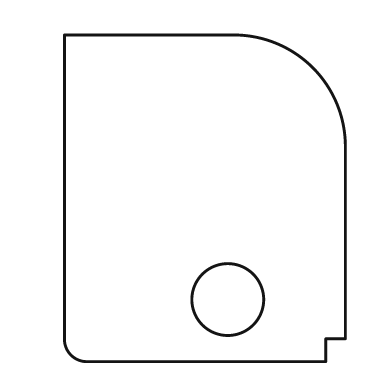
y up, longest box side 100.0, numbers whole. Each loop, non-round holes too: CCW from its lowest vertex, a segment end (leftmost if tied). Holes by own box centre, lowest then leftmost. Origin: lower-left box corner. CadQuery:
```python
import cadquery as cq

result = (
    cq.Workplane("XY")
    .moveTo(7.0, 0.0)
    .lineTo(80.0, 0.0)
    .lineTo(80.0, 7.0)
    .lineTo(86.0, 7.0)
    .lineTo(86.0, 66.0)
    .threePointArc((76.0, 90.0), (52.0, 100.0))
    .lineTo(0.0, 100.0)
    .lineTo(0.0, 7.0)
    .threePointArc((2.0, 2.0), (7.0, 0.0))
    .close()
    .moveTo(50.0, 19.0)
    .circle(11.0)
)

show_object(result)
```